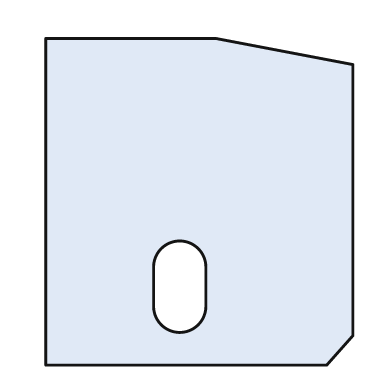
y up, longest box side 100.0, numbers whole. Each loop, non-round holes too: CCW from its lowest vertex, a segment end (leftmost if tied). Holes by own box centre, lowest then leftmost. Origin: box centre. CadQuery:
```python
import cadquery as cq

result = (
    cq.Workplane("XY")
    .moveTo(-47.0, -50.0)
    .lineTo(39.0, -50.0)
    .lineTo(47.0, -41.0)
    .lineTo(47.0, 42.0)
    .lineTo(5.0, 50.0)
    .lineTo(-47.0, 50.0)
    .close()
    .moveTo(-14.0, -32.0)
    .threePointArc((-6.0, -40.0), (2.0, -32.0))
    .lineTo(2.0, -20.0)
    .threePointArc((-6.0, -12.0), (-14.0, -20.0))
    .close()
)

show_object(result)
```